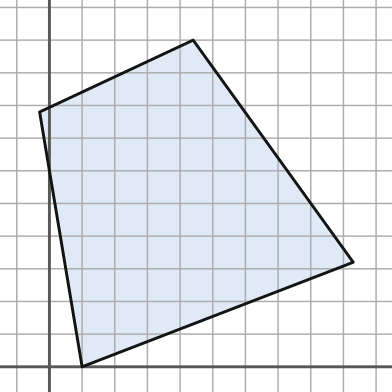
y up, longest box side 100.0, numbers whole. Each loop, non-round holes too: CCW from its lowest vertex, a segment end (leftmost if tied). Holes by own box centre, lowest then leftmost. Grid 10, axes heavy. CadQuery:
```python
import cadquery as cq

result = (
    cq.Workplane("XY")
    .moveTo(10.0, 0.0)
    .lineTo(93.0, 32.0)
    .lineTo(44.0, 100.0)
    .lineTo(-3.0, 78.0)
    .close()
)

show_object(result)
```